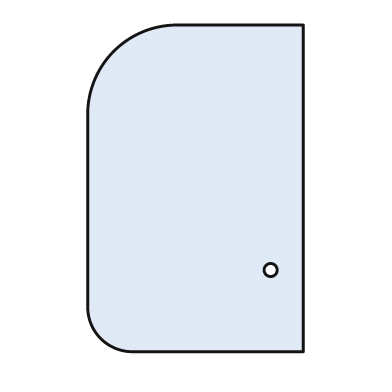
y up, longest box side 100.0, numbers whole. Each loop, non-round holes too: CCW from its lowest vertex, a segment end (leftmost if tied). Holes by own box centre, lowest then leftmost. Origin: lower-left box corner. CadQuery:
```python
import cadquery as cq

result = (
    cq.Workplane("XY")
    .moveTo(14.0, 0.0)
    .lineTo(66.0, 0.0)
    .lineTo(66.0, 100.0)
    .lineTo(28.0, 100.0)
    .threePointArc((8.0, 92.0), (0.0, 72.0))
    .lineTo(0.0, 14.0)
    .threePointArc((4.0, 4.0), (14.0, 0.0))
    .close()
    .moveTo(56.0, 25.0)
    .circle(2.0)
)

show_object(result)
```